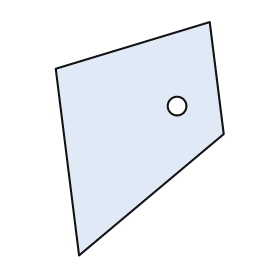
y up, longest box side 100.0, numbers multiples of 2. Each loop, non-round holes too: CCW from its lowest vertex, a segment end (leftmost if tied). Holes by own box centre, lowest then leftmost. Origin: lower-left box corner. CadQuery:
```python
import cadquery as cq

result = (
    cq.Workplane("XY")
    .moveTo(10.0, 0.0)
    .lineTo(72.0, 52.0)
    .lineTo(66.0, 100.0)
    .lineTo(0.0, 80.0)
    .close()
    .moveTo(52.0, 64.0)
    .circle(4.0)
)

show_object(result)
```